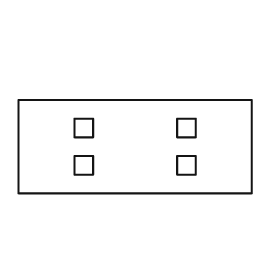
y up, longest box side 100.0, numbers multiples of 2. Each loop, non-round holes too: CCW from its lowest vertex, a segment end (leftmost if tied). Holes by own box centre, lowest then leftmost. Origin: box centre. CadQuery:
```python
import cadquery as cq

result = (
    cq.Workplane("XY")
    .moveTo(-50.0, -20.0)
    .lineTo(50.0, -20.0)
    .lineTo(50.0, 20.0)
    .lineTo(-50.0, 20.0)
    .close()
    .moveTo(-26.0, -12.0)
    .lineTo(-18.0, -12.0)
    .lineTo(-18.0, -4.0)
    .lineTo(-26.0, -4.0)
    .close()
    .moveTo(18.0, -12.0)
    .lineTo(26.0, -12.0)
    .lineTo(26.0, -4.0)
    .lineTo(18.0, -4.0)
    .close()
    .moveTo(-26.0, 4.0)
    .lineTo(-18.0, 4.0)
    .lineTo(-18.0, 12.0)
    .lineTo(-26.0, 12.0)
    .close()
    .moveTo(18.0, 4.0)
    .lineTo(26.0, 4.0)
    .lineTo(26.0, 12.0)
    .lineTo(18.0, 12.0)
    .close()
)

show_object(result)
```